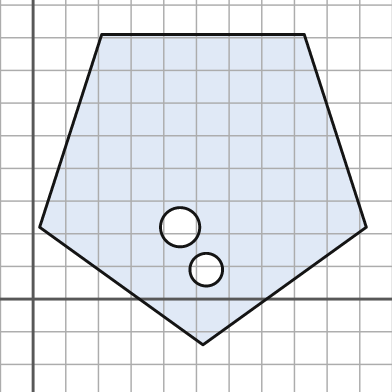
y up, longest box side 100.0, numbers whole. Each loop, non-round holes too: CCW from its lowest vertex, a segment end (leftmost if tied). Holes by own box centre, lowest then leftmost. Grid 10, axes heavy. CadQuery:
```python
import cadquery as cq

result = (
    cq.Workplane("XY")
    .moveTo(52.0, -14.0)
    .lineTo(102.0, 22.0)
    .lineTo(83.0, 81.0)
    .lineTo(21.0, 81.0)
    .lineTo(2.0, 22.0)
    .close()
    .moveTo(53.0, 9.0)
    .circle(5.0)
    .moveTo(45.0, 22.0)
    .circle(6.0)
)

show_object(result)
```